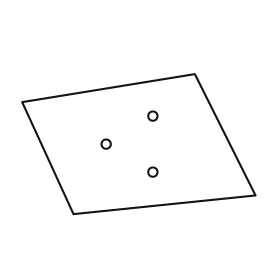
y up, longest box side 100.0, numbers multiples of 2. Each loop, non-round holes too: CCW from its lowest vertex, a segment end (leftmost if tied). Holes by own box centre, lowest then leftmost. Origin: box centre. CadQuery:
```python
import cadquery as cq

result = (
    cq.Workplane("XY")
    .moveTo(-28.0, -30.0)
    .lineTo(50.0, -22.0)
    .lineTo(24.0, 30.0)
    .lineTo(-50.0, 18.0)
    .close()
    .moveTo(6.0, -12.0)
    .circle(2.0)
    .moveTo(-14.0, 0.0)
    .circle(2.0)
    .moveTo(6.0, 12.0)
    .circle(2.0)
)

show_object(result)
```